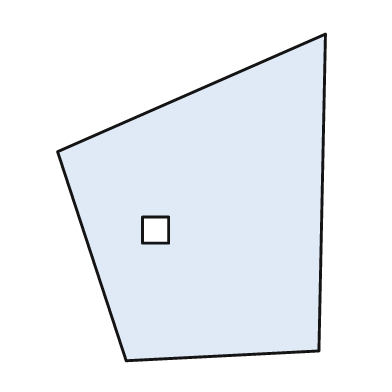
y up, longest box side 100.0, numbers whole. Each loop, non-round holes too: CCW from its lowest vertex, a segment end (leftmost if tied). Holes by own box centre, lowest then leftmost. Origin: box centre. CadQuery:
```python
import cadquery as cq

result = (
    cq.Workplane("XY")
    .moveTo(-20.0, -50.0)
    .lineTo(39.0, -47.0)
    .lineTo(41.0, 50.0)
    .lineTo(-41.0, 14.0)
    .close()
    .moveTo(-15.0, -14.0)
    .lineTo(-7.0, -14.0)
    .lineTo(-7.0, -6.0)
    .lineTo(-15.0, -6.0)
    .close()
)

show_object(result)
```